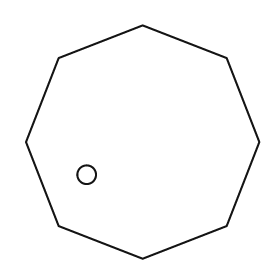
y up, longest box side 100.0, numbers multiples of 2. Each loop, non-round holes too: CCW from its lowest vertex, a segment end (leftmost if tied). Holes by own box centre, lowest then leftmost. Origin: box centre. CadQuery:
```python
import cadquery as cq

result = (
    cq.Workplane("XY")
    .moveTo(0.0, -50.0)
    .lineTo(36.0, -36.0)
    .lineTo(50.0, 0.0)
    .lineTo(36.0, 36.0)
    .lineTo(0.0, 50.0)
    .lineTo(-36.0, 36.0)
    .lineTo(-50.0, 0.0)
    .lineTo(-36.0, -36.0)
    .close()
    .moveTo(-24.0, -14.0)
    .circle(4.0)
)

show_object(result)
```